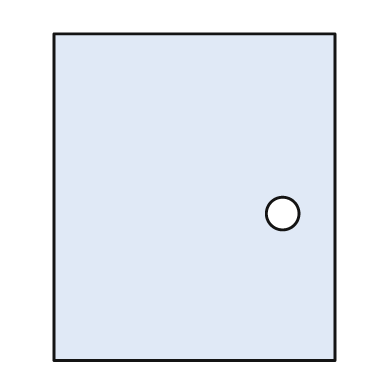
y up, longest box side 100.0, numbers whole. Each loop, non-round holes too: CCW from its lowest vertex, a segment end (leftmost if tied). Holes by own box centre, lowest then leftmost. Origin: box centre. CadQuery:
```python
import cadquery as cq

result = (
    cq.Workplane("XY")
    .moveTo(-43.0, -50.0)
    .lineTo(43.0, -50.0)
    .lineTo(43.0, 50.0)
    .lineTo(-43.0, 50.0)
    .close()
    .moveTo(27.0, -5.0)
    .circle(5.0)
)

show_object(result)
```